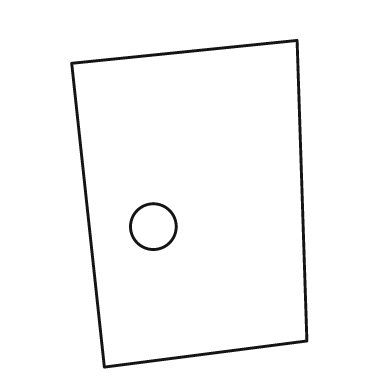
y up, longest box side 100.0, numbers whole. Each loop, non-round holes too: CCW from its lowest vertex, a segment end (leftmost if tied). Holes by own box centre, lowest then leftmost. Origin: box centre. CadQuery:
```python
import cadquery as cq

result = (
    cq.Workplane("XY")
    .moveTo(-26.0, -50.0)
    .lineTo(36.0, -42.0)
    .lineTo(33.0, 50.0)
    .lineTo(-36.0, 43.0)
    .close()
    .moveTo(-11.0, -7.0)
    .circle(7.0)
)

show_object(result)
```